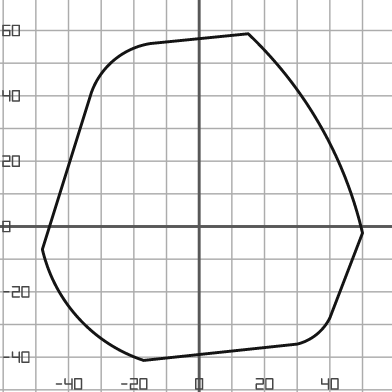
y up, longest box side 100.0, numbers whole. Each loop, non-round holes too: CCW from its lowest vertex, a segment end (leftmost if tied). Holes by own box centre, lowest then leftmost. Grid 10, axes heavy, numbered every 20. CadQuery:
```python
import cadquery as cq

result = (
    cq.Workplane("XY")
    .moveTo(-17.0, -41.0)
    .lineTo(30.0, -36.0)
    .threePointArc((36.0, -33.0), (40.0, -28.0))
    .lineTo(50.0, -2.0)
    .threePointArc((37.0, 31.0), (15.0, 59.0))
    .lineTo(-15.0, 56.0)
    .threePointArc((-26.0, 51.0), (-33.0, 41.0))
    .lineTo(-48.0, -7.0)
    .threePointArc((-37.0, -28.0), (-17.0, -41.0))
    .close()
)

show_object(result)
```